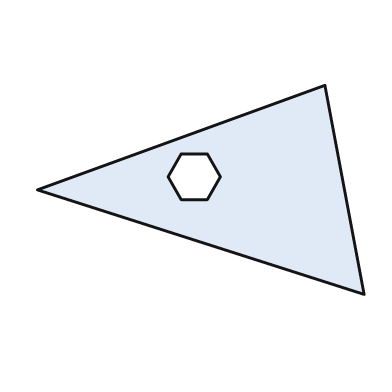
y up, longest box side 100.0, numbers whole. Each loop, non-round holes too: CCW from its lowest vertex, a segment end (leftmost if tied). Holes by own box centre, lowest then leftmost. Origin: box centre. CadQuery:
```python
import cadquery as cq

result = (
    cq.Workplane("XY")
    .moveTo(50.0, -32.0)
    .lineTo(38.0, 32.0)
    .lineTo(-50.0, 0.0)
    .close()
    .moveTo(-6.0, -3.0)
    .lineTo(2.0, -3.0)
    .lineTo(6.0, 4.0)
    .lineTo(2.0, 11.0)
    .lineTo(-6.0, 11.0)
    .lineTo(-10.0, 4.0)
    .close()
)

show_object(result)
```